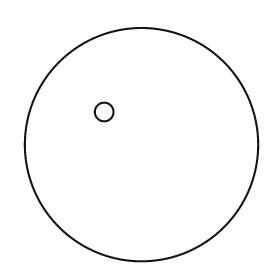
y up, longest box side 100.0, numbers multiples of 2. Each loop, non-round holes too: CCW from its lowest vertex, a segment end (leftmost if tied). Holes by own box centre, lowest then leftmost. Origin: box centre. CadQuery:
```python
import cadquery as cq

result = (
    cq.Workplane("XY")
    .moveTo(0.0, 0.0)
    .circle(50.0)
    .moveTo(-16.0, 14.0)
    .circle(4.0)
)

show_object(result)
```